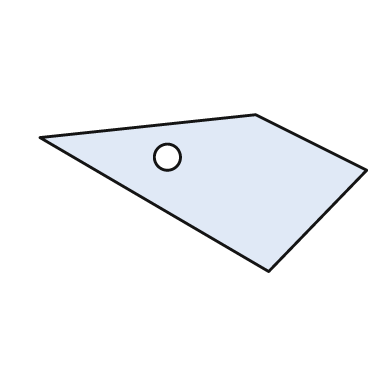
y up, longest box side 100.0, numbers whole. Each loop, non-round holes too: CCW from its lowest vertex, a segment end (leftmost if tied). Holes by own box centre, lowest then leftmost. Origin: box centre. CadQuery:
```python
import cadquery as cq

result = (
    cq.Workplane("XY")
    .moveTo(20.0, -24.0)
    .lineTo(50.0, 7.0)
    .lineTo(16.0, 24.0)
    .lineTo(-50.0, 17.0)
    .close()
    .moveTo(-11.0, 11.0)
    .circle(4.0)
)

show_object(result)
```